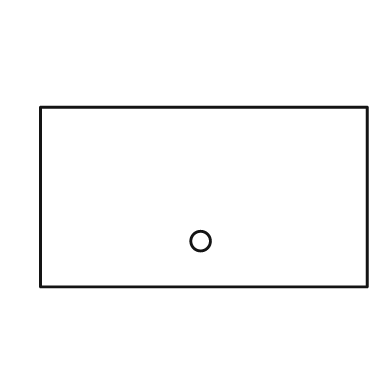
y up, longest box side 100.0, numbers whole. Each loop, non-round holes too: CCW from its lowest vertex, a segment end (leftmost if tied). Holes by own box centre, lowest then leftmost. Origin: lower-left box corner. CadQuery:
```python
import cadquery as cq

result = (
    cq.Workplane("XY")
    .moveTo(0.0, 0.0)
    .lineTo(100.0, 0.0)
    .lineTo(100.0, 55.0)
    .lineTo(0.0, 55.0)
    .close()
    .moveTo(49.0, 14.0)
    .circle(3.0)
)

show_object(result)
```